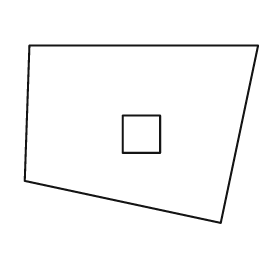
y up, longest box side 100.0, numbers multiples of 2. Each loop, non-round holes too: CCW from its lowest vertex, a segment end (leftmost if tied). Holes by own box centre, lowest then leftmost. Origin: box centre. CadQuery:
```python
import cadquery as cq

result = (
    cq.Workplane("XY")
    .moveTo(34.0, -38.0)
    .lineTo(50.0, 38.0)
    .lineTo(-48.0, 38.0)
    .lineTo(-50.0, -20.0)
    .close()
    .moveTo(-8.0, -8.0)
    .lineTo(8.0, -8.0)
    .lineTo(8.0, 8.0)
    .lineTo(-8.0, 8.0)
    .close()
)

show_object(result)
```